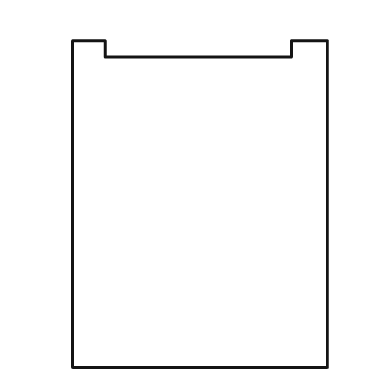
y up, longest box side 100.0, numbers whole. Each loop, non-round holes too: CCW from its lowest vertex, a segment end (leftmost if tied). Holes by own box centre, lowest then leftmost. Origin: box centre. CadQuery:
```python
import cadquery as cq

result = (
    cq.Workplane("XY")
    .moveTo(-39.0, -50.0)
    .lineTo(39.0, -50.0)
    .lineTo(39.0, 50.0)
    .lineTo(28.0, 50.0)
    .lineTo(28.0, 45.0)
    .lineTo(-29.0, 45.0)
    .lineTo(-29.0, 50.0)
    .lineTo(-39.0, 50.0)
    .close()
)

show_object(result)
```